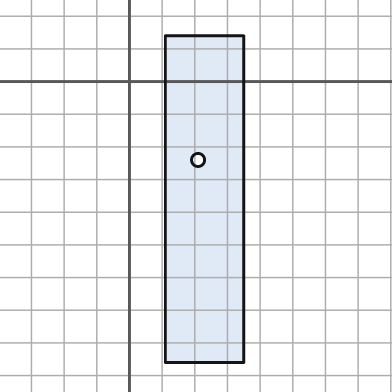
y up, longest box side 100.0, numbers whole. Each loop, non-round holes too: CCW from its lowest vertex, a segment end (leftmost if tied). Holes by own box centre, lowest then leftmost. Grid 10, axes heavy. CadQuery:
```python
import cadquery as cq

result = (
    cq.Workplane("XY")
    .moveTo(11.0, -86.0)
    .lineTo(35.0, -86.0)
    .lineTo(35.0, 14.0)
    .lineTo(11.0, 14.0)
    .close()
    .moveTo(21.0, -24.0)
    .circle(2.0)
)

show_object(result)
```